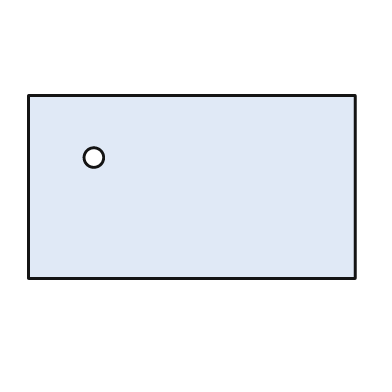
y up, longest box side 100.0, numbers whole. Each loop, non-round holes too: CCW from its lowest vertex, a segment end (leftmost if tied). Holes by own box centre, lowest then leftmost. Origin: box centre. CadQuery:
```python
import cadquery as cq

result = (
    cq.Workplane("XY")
    .moveTo(-50.0, -28.0)
    .lineTo(50.0, -28.0)
    .lineTo(50.0, 28.0)
    .lineTo(-50.0, 28.0)
    .close()
    .moveTo(-30.0, 9.0)
    .circle(3.0)
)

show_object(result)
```